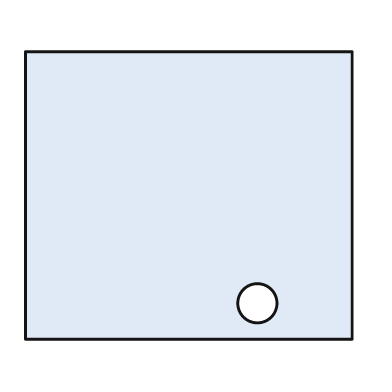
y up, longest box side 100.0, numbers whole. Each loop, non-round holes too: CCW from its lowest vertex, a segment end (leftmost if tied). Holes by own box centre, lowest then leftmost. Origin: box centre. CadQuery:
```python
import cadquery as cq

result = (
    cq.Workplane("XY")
    .moveTo(-50.0, -44.0)
    .lineTo(50.0, -44.0)
    .lineTo(50.0, 44.0)
    .lineTo(-50.0, 44.0)
    .close()
    .moveTo(21.0, -33.0)
    .circle(6.0)
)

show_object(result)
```